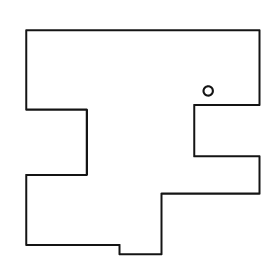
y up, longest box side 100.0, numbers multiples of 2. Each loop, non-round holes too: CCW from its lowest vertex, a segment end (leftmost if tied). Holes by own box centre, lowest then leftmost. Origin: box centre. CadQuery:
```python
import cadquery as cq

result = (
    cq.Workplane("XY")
    .moveTo(-10.0, -48.0)
    .lineTo(8.0, -48.0)
    .lineTo(8.0, -22.0)
    .lineTo(50.0, -22.0)
    .lineTo(50.0, -6.0)
    .lineTo(22.0, -6.0)
    .lineTo(22.0, 16.0)
    .lineTo(50.0, 16.0)
    .lineTo(50.0, 48.0)
    .lineTo(-50.0, 48.0)
    .lineTo(-50.0, 14.0)
    .lineTo(-24.0, 14.0)
    .lineTo(-24.0, -14.0)
    .lineTo(-50.0, -14.0)
    .lineTo(-50.0, -44.0)
    .lineTo(-10.0, -44.0)
    .close()
    .moveTo(28.0, 22.0)
    .circle(2.0)
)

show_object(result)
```